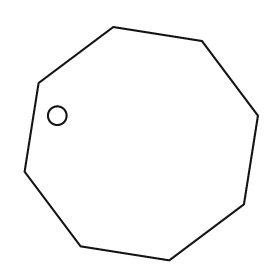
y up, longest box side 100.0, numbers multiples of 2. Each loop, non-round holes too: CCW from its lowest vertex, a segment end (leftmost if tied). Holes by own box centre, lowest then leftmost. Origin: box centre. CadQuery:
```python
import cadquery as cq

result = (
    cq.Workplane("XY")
    .moveTo(12.0, -50.0)
    .lineTo(44.0, -26.0)
    .lineTo(50.0, 12.0)
    .lineTo(26.0, 44.0)
    .lineTo(-12.0, 50.0)
    .lineTo(-44.0, 26.0)
    .lineTo(-50.0, -12.0)
    .lineTo(-26.0, -44.0)
    .close()
    .moveTo(-36.0, 12.0)
    .circle(4.0)
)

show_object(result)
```